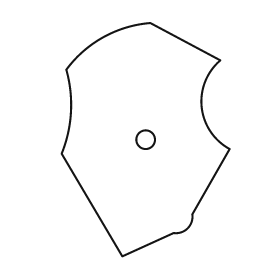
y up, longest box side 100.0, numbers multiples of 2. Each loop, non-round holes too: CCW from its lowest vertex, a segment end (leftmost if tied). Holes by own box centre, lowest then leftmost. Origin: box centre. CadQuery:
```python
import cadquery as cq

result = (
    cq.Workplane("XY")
    .moveTo(-10.0, -50.0)
    .lineTo(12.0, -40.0)
    .threePointArc((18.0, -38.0), (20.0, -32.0))
    .lineTo(36.0, -4.0)
    .threePointArc((24.0, 14.0), (32.0, 34.0))
    .lineTo(2.0, 50.0)
    .threePointArc((-18.0, 44.0), (-34.0, 30.0))
    .threePointArc((-32.0, 12.0), (-36.0, -6.0))
    .close()
    .moveTo(0.0, 0.0)
    .circle(4.0)
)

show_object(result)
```